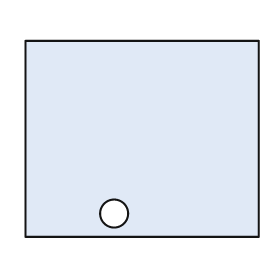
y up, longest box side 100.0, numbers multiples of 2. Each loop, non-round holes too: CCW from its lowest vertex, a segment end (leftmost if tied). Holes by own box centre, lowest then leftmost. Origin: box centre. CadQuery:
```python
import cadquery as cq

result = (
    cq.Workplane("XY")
    .moveTo(-50.0, -42.0)
    .lineTo(50.0, -42.0)
    .lineTo(50.0, 42.0)
    .lineTo(-50.0, 42.0)
    .close()
    .moveTo(-12.0, -32.0)
    .circle(6.0)
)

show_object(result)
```